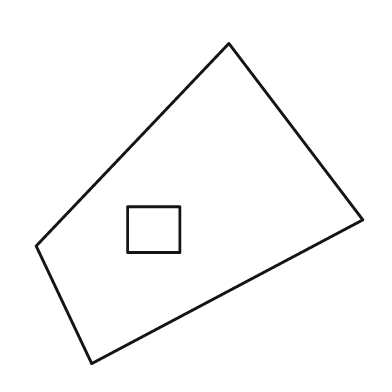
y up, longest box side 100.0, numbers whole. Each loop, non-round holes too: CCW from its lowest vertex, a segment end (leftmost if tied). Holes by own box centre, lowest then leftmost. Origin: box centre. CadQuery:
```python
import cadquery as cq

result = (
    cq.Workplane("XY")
    .moveTo(-33.0, -49.0)
    .lineTo(50.0, -5.0)
    .lineTo(9.0, 49.0)
    .lineTo(-50.0, -13.0)
    .close()
    .moveTo(-22.0, -15.0)
    .lineTo(-6.0, -15.0)
    .lineTo(-6.0, -1.0)
    .lineTo(-22.0, -1.0)
    .close()
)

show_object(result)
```